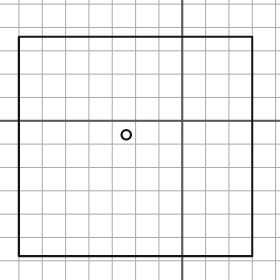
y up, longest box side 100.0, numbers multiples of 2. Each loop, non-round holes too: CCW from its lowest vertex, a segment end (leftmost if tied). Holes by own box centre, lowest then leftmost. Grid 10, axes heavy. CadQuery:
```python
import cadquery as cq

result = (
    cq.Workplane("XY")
    .moveTo(-70.0, -58.0)
    .lineTo(30.0, -58.0)
    .lineTo(30.0, 36.0)
    .lineTo(-70.0, 36.0)
    .close()
    .moveTo(-24.0, -6.0)
    .circle(2.0)
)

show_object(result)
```